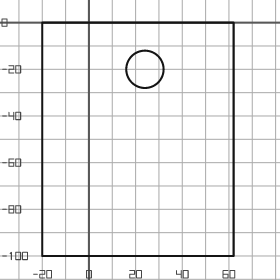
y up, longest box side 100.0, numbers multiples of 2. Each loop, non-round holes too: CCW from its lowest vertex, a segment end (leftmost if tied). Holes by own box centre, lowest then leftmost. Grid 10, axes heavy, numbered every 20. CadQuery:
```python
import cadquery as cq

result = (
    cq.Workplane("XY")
    .moveTo(-20.0, -100.0)
    .lineTo(62.0, -100.0)
    .lineTo(62.0, 0.0)
    .lineTo(-20.0, 0.0)
    .close()
    .moveTo(24.0, -20.0)
    .circle(8.0)
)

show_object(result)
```